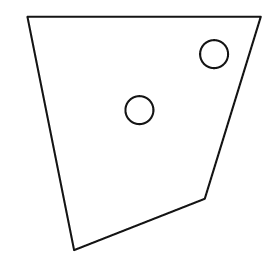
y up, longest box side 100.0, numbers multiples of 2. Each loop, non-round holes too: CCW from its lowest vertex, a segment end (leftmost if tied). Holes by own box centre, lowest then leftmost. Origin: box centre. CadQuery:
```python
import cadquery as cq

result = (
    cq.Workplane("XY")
    .moveTo(-30.0, -50.0)
    .lineTo(26.0, -28.0)
    .lineTo(50.0, 50.0)
    .lineTo(-50.0, 50.0)
    .close()
    .moveTo(-2.0, 10.0)
    .circle(6.0)
    .moveTo(30.0, 34.0)
    .circle(6.0)
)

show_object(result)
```